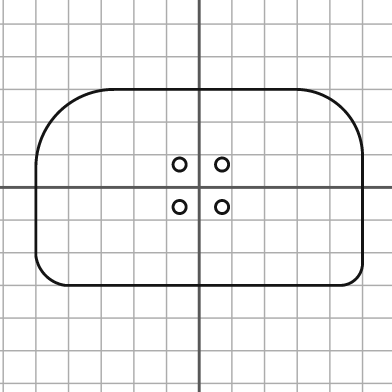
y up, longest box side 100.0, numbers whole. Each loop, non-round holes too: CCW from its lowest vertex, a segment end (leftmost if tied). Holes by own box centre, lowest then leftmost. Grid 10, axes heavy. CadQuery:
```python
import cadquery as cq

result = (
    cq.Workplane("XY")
    .moveTo(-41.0, -30.0)
    .lineTo(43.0, -30.0)
    .threePointArc((48.0, -28.0), (50.0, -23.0))
    .lineTo(50.0, 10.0)
    .threePointArc((44.0, 24.0), (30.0, 30.0))
    .lineTo(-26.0, 30.0)
    .threePointArc((-43.0, 23.0), (-50.0, 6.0))
    .lineTo(-50.0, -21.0)
    .threePointArc((-47.0, -27.0), (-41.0, -30.0))
    .close()
    .moveTo(-6.0, -6.0)
    .circle(2.0)
    .moveTo(7.0, -6.0)
    .circle(2.0)
    .moveTo(-6.0, 7.0)
    .circle(2.0)
    .moveTo(7.0, 7.0)
    .circle(2.0)
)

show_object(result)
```